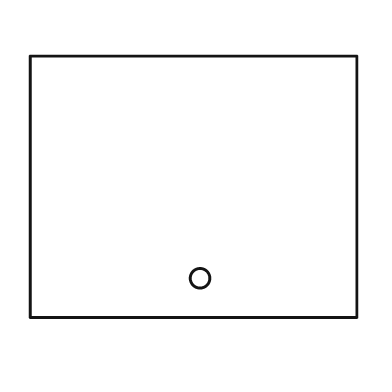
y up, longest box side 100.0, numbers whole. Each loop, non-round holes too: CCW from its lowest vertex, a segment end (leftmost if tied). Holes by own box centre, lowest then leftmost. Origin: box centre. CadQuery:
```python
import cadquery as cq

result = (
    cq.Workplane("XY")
    .moveTo(-50.0, -40.0)
    .lineTo(50.0, -40.0)
    .lineTo(50.0, 40.0)
    .lineTo(-50.0, 40.0)
    .close()
    .moveTo(2.0, -28.0)
    .circle(3.0)
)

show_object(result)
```